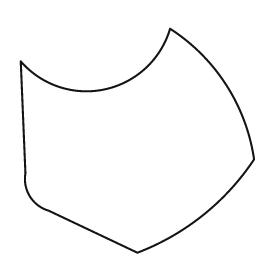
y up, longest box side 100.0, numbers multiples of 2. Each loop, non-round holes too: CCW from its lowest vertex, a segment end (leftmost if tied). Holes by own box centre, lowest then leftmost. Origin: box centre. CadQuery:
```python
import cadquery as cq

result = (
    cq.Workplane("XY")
    .moveTo(0.0, -48.0)
    .threePointArc((28.0, -32.0), (50.0, -8.0))
    .threePointArc((38.0, 24.0), (14.0, 48.0))
    .threePointArc((-14.0, 22.0), (-50.0, 34.0))
    .lineTo(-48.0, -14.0)
    .threePointArc((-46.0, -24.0), (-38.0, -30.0))
    .close()
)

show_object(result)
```